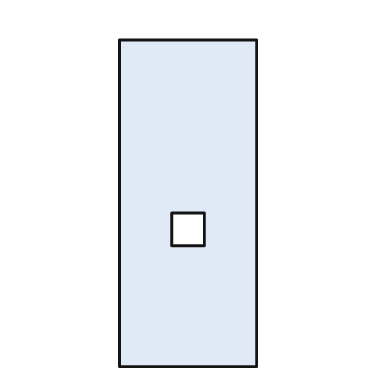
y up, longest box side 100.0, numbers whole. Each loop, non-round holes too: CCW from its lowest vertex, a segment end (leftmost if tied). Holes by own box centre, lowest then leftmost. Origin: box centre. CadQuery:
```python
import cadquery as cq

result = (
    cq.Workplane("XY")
    .moveTo(-21.0, -50.0)
    .lineTo(21.0, -50.0)
    .lineTo(21.0, 50.0)
    .lineTo(-21.0, 50.0)
    .close()
    .moveTo(-5.0, -13.0)
    .lineTo(5.0, -13.0)
    .lineTo(5.0, -3.0)
    .lineTo(-5.0, -3.0)
    .close()
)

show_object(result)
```